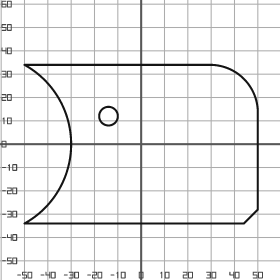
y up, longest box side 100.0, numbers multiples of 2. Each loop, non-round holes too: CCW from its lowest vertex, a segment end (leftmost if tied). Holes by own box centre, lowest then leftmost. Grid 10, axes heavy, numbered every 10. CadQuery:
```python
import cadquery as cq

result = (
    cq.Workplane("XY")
    .moveTo(-50.0, -34.0)
    .lineTo(44.0, -34.0)
    .lineTo(50.0, -28.0)
    .lineTo(50.0, 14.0)
    .threePointArc((44.0, 28.0), (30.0, 34.0))
    .lineTo(-50.0, 34.0)
    .threePointArc((-30.0, 0.0), (-50.0, -34.0))
    .close()
    .moveTo(-14.0, 12.0)
    .circle(4.0)
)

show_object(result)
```